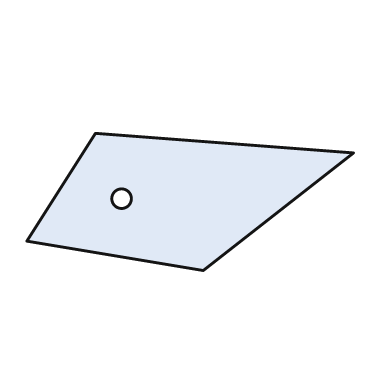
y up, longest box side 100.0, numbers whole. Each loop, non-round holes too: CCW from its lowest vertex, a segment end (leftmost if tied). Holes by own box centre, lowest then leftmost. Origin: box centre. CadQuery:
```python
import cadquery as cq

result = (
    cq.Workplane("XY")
    .moveTo(4.0, -21.0)
    .lineTo(50.0, 15.0)
    .lineTo(-29.0, 21.0)
    .lineTo(-50.0, -12.0)
    .close()
    .moveTo(-21.0, 1.0)
    .circle(3.0)
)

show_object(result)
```